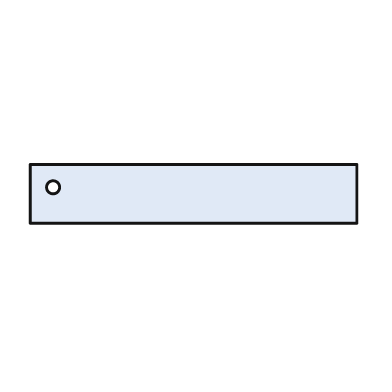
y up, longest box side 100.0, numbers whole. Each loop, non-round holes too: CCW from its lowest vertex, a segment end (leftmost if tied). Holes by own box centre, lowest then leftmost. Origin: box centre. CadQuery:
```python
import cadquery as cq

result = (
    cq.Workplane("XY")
    .moveTo(-50.0, -9.0)
    .lineTo(50.0, -9.0)
    .lineTo(50.0, 9.0)
    .lineTo(-50.0, 9.0)
    .close()
    .moveTo(-43.0, 2.0)
    .circle(2.0)
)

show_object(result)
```